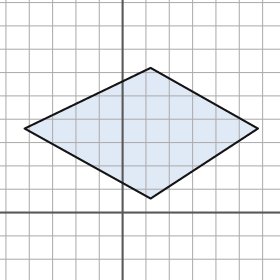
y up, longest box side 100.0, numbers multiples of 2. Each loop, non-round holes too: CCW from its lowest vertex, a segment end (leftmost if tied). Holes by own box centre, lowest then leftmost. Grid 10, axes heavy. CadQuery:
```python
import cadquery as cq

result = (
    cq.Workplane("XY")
    .moveTo(12.0, 6.0)
    .lineTo(58.0, 36.0)
    .lineTo(12.0, 62.0)
    .lineTo(-42.0, 36.0)
    .close()
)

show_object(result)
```